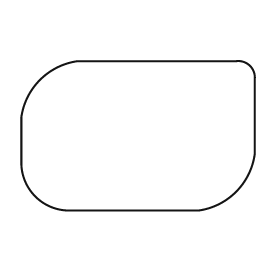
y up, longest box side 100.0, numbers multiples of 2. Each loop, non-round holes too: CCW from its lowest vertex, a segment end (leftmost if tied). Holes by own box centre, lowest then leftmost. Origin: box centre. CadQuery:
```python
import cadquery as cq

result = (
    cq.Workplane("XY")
    .moveTo(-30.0, -32.0)
    .lineTo(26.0, -32.0)
    .threePointArc((42.0, -24.0), (50.0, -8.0))
    .lineTo(50.0, 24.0)
    .threePointArc((48.0, 30.0), (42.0, 32.0))
    .lineTo(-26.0, 32.0)
    .threePointArc((-42.0, 24.0), (-50.0, 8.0))
    .lineTo(-50.0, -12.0)
    .threePointArc((-44.0, -26.0), (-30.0, -32.0))
    .close()
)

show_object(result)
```